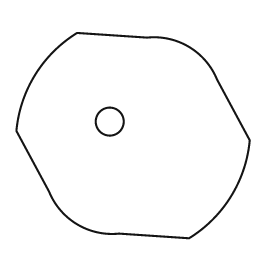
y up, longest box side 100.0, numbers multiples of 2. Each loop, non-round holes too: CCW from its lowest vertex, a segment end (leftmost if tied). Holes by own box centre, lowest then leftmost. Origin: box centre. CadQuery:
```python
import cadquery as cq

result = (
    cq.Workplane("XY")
    .moveTo(24.0, -44.0)
    .threePointArc((42.0, -26.0), (50.0, -2.0))
    .lineTo(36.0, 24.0)
    .threePointArc((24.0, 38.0), (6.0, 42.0))
    .lineTo(-24.0, 44.0)
    .threePointArc((-42.0, 26.0), (-50.0, 2.0))
    .lineTo(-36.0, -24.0)
    .threePointArc((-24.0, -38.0), (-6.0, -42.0))
    .close()
    .moveTo(-10.0, 6.0)
    .circle(6.0)
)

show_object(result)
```